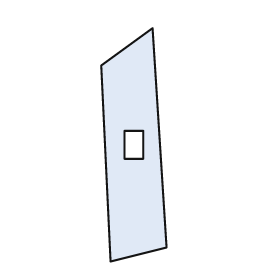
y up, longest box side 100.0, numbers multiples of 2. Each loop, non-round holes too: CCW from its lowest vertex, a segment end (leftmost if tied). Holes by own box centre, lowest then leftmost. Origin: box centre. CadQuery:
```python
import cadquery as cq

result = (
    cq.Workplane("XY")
    .moveTo(-10.0, -50.0)
    .lineTo(14.0, -44.0)
    .lineTo(8.0, 50.0)
    .lineTo(-14.0, 34.0)
    .close()
    .moveTo(-4.0, -6.0)
    .lineTo(4.0, -6.0)
    .lineTo(4.0, 6.0)
    .lineTo(-4.0, 6.0)
    .close()
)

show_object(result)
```